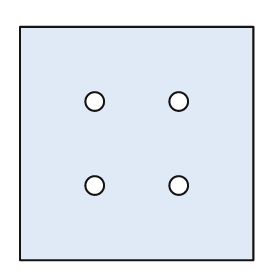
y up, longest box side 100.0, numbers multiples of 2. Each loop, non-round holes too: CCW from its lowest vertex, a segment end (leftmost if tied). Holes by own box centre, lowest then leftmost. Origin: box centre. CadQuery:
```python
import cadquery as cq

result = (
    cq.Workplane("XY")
    .moveTo(-50.0, -50.0)
    .lineTo(50.0, -50.0)
    .lineTo(50.0, 50.0)
    .lineTo(-50.0, 50.0)
    .close()
    .moveTo(-18.0, -18.0)
    .circle(4.0)
    .moveTo(18.0, -18.0)
    .circle(4.0)
    .moveTo(-18.0, 18.0)
    .circle(4.0)
    .moveTo(18.0, 18.0)
    .circle(4.0)
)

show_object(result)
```